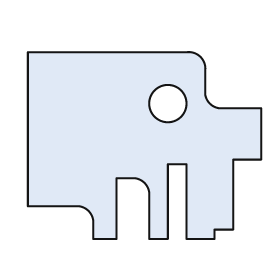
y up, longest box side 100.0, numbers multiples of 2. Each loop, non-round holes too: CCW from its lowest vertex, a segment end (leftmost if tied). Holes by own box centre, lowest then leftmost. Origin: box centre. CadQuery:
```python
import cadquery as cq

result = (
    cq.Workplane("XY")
    .moveTo(-22.0, -40.0)
    .lineTo(-12.0, -40.0)
    .lineTo(-12.0, -14.0)
    .lineTo(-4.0, -14.0)
    .threePointArc((0.0, -16.0), (2.0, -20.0))
    .lineTo(2.0, -40.0)
    .lineTo(10.0, -40.0)
    .lineTo(10.0, -8.0)
    .lineTo(18.0, -8.0)
    .lineTo(18.0, -40.0)
    .lineTo(30.0, -40.0)
    .lineTo(30.0, -36.0)
    .lineTo(38.0, -36.0)
    .lineTo(38.0, -6.0)
    .lineTo(50.0, -6.0)
    .lineTo(50.0, 16.0)
    .lineTo(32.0, 16.0)
    .threePointArc((28.0, 18.0), (26.0, 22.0))
    .lineTo(26.0, 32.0)
    .threePointArc((24.0, 38.0), (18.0, 40.0))
    .lineTo(-50.0, 40.0)
    .lineTo(-50.0, -26.0)
    .lineTo(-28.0, -26.0)
    .threePointArc((-24.0, -28.0), (-22.0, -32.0))
    .close()
    .moveTo(10.0, 18.0)
    .circle(8.0)
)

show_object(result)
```